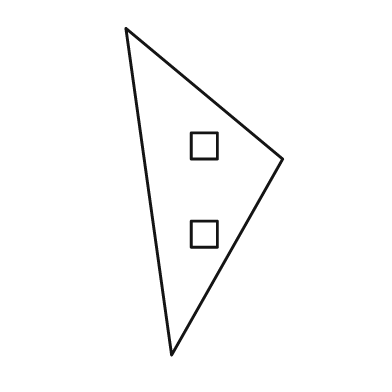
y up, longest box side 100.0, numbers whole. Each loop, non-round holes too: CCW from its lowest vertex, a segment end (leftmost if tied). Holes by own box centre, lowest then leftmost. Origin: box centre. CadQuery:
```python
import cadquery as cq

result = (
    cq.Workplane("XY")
    .moveTo(-10.0, -50.0)
    .lineTo(24.0, 10.0)
    .lineTo(-24.0, 50.0)
    .close()
    .moveTo(-4.0, -17.0)
    .lineTo(4.0, -17.0)
    .lineTo(4.0, -9.0)
    .lineTo(-4.0, -9.0)
    .close()
    .moveTo(-4.0, 10.0)
    .lineTo(4.0, 10.0)
    .lineTo(4.0, 18.0)
    .lineTo(-4.0, 18.0)
    .close()
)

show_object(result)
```